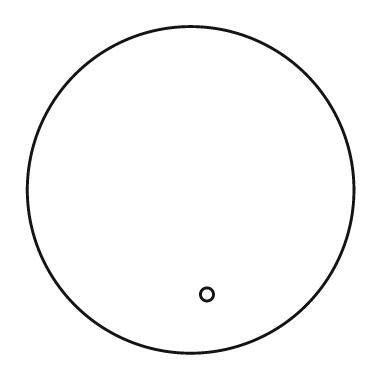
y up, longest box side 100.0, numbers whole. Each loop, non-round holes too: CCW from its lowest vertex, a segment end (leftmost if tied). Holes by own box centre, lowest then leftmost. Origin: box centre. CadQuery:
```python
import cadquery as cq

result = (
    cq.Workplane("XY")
    .moveTo(0.0, 0.0)
    .circle(50.0)
    .moveTo(5.0, -32.0)
    .circle(2.0)
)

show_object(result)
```